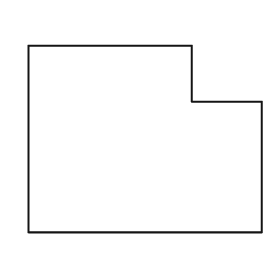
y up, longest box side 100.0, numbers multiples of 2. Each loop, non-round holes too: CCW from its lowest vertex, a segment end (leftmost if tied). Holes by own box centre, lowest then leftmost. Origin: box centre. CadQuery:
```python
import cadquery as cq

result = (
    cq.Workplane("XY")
    .moveTo(-50.0, -40.0)
    .lineTo(50.0, -40.0)
    .lineTo(50.0, 16.0)
    .lineTo(20.0, 16.0)
    .lineTo(20.0, 40.0)
    .lineTo(-50.0, 40.0)
    .close()
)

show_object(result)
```